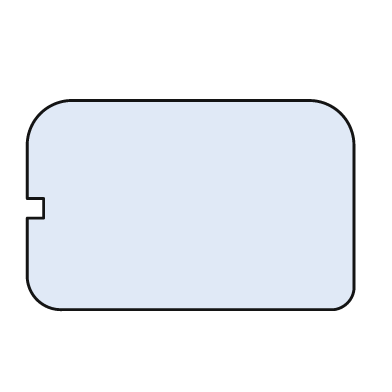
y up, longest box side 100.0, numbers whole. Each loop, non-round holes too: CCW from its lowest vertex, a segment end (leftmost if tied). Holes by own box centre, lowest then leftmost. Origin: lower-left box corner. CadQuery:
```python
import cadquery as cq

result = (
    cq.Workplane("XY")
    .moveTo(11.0, 0.0)
    .lineTo(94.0, 0.0)
    .threePointArc((98.0, 2.0), (100.0, 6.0))
    .lineTo(100.0, 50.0)
    .threePointArc((96.0, 60.0), (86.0, 64.0))
    .lineTo(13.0, 64.0)
    .threePointArc((4.0, 60.0), (0.0, 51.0))
    .lineTo(0.0, 34.0)
    .lineTo(5.0, 34.0)
    .lineTo(5.0, 28.0)
    .lineTo(0.0, 28.0)
    .lineTo(0.0, 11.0)
    .threePointArc((3.0, 3.0), (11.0, 0.0))
    .close()
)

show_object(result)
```